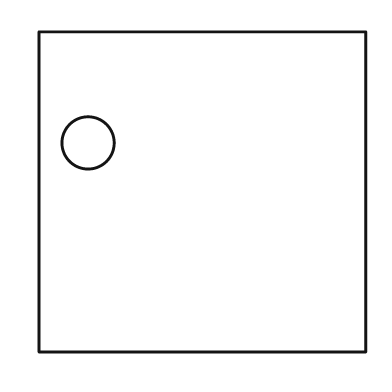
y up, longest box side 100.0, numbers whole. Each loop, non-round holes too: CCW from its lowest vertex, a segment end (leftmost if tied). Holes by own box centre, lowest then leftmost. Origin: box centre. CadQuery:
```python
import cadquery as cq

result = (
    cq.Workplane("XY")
    .moveTo(-50.0, -49.0)
    .lineTo(50.0, -49.0)
    .lineTo(50.0, 49.0)
    .lineTo(-50.0, 49.0)
    .close()
    .moveTo(-35.0, 15.0)
    .circle(8.0)
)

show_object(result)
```